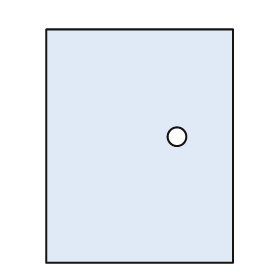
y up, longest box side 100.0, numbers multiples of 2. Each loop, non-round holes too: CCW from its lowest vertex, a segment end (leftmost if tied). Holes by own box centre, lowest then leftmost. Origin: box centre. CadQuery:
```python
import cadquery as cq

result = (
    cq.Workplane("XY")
    .moveTo(-40.0, -50.0)
    .lineTo(40.0, -50.0)
    .lineTo(40.0, 50.0)
    .lineTo(-40.0, 50.0)
    .close()
    .moveTo(16.0, 4.0)
    .circle(4.0)
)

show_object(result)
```